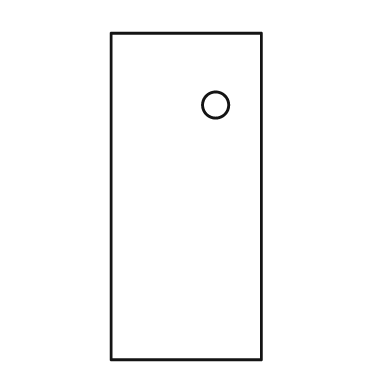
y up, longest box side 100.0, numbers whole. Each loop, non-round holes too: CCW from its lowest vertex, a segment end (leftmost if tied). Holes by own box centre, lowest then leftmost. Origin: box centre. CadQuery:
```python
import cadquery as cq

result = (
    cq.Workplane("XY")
    .moveTo(-23.0, -50.0)
    .lineTo(23.0, -50.0)
    .lineTo(23.0, 50.0)
    .lineTo(-23.0, 50.0)
    .close()
    .moveTo(9.0, 28.0)
    .circle(4.0)
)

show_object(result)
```